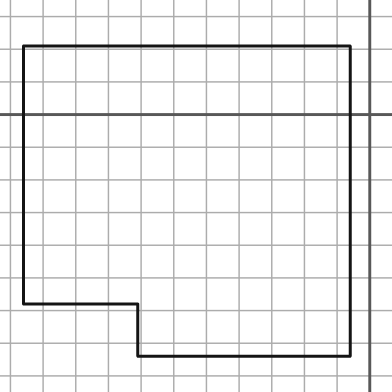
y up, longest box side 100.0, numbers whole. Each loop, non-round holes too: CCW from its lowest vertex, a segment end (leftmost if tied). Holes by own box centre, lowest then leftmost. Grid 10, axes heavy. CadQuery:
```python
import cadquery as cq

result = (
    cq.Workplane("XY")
    .moveTo(-71.0, -74.0)
    .lineTo(-6.0, -74.0)
    .lineTo(-6.0, 21.0)
    .lineTo(-106.0, 21.0)
    .lineTo(-106.0, -58.0)
    .lineTo(-71.0, -58.0)
    .close()
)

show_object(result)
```